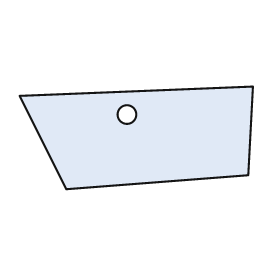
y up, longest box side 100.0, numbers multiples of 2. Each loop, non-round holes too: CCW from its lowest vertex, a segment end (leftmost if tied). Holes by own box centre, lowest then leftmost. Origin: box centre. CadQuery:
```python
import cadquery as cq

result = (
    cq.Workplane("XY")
    .moveTo(-30.0, -22.0)
    .lineTo(48.0, -16.0)
    .lineTo(50.0, 22.0)
    .lineTo(-50.0, 18.0)
    .close()
    .moveTo(-4.0, 10.0)
    .circle(4.0)
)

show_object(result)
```